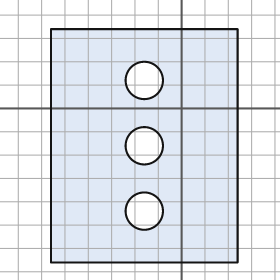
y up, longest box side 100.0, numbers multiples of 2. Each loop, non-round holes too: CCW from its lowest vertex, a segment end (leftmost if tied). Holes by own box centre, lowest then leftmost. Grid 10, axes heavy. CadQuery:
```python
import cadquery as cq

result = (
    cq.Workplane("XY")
    .moveTo(-56.0, -66.0)
    .lineTo(24.0, -66.0)
    .lineTo(24.0, 34.0)
    .lineTo(-56.0, 34.0)
    .close()
    .moveTo(-16.0, -44.0)
    .circle(8.0)
    .moveTo(-16.0, -16.0)
    .circle(8.0)
    .moveTo(-16.0, 12.0)
    .circle(8.0)
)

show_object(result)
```